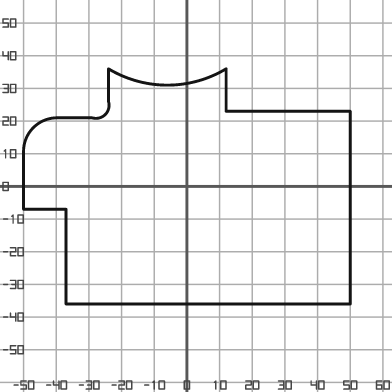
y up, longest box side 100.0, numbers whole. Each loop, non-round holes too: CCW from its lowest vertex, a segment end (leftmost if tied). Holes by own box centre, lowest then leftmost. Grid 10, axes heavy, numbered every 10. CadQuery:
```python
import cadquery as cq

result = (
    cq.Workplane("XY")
    .moveTo(-37.0, -36.0)
    .lineTo(50.0, -36.0)
    .lineTo(50.0, 23.0)
    .lineTo(12.0, 23.0)
    .lineTo(12.0, 36.0)
    .threePointArc((-6.0, 31.0), (-24.0, 36.0))
    .lineTo(-24.0, 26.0)
    .threePointArc((-25.0, 22.0), (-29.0, 21.0))
    .lineTo(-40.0, 21.0)
    .threePointArc((-47.0, 18.0), (-50.0, 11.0))
    .lineTo(-50.0, -7.0)
    .lineTo(-37.0, -7.0)
    .close()
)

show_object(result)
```